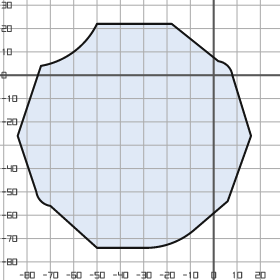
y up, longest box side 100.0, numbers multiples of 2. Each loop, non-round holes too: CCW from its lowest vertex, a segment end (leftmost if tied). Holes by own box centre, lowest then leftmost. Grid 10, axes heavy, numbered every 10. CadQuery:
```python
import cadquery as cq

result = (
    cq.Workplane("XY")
    .moveTo(-50.0, -74.0)
    .lineTo(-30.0, -74.0)
    .threePointArc((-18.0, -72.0), (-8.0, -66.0))
    .lineTo(6.0, -54.0)
    .lineTo(16.0, -26.0)
    .lineTo(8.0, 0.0)
    .threePointArc((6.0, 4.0), (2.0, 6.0))
    .lineTo(-18.0, 22.0)
    .lineTo(-50.0, 22.0)
    .threePointArc((-60.0, 10.0), (-74.0, 4.0))
    .lineTo(-84.0, -26.0)
    .lineTo(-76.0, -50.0)
    .threePointArc((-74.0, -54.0), (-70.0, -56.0))
    .close()
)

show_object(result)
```